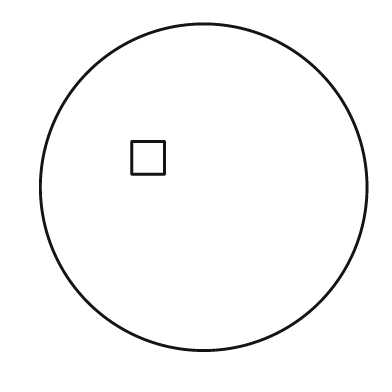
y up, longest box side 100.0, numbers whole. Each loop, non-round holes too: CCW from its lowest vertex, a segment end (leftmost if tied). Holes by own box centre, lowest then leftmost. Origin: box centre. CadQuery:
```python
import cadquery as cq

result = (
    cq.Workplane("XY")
    .moveTo(0.0, 0.0)
    .circle(50.0)
    .moveTo(-22.0, 4.0)
    .lineTo(-12.0, 4.0)
    .lineTo(-12.0, 14.0)
    .lineTo(-22.0, 14.0)
    .close()
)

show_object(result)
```